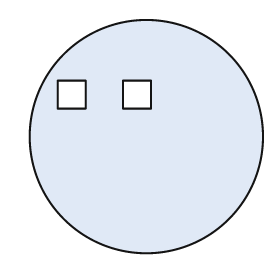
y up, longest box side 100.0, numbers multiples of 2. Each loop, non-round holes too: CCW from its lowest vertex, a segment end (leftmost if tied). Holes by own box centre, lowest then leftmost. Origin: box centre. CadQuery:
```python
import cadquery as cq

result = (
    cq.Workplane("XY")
    .moveTo(0.0, 0.0)
    .circle(50.0)
    .moveTo(-38.0, 12.0)
    .lineTo(-26.0, 12.0)
    .lineTo(-26.0, 24.0)
    .lineTo(-38.0, 24.0)
    .close()
    .moveTo(-10.0, 12.0)
    .lineTo(2.0, 12.0)
    .lineTo(2.0, 24.0)
    .lineTo(-10.0, 24.0)
    .close()
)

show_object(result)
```